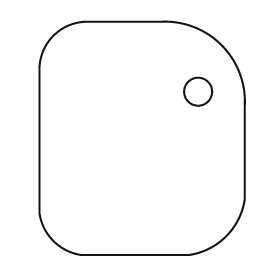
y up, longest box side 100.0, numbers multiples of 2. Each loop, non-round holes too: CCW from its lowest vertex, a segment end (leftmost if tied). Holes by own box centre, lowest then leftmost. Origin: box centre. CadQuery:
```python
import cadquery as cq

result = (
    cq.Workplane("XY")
    .moveTo(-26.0, -50.0)
    .lineTo(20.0, -50.0)
    .threePointArc((36.0, -42.0), (44.0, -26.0))
    .lineTo(44.0, 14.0)
    .threePointArc((34.0, 40.0), (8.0, 50.0))
    .lineTo(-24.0, 50.0)
    .threePointArc((-38.0, 44.0), (-44.0, 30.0))
    .lineTo(-44.0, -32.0)
    .threePointArc((-38.0, -44.0), (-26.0, -50.0))
    .close()
    .moveTo(24.0, 20.0)
    .circle(6.0)
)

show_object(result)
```